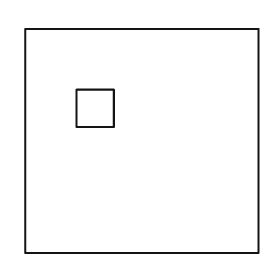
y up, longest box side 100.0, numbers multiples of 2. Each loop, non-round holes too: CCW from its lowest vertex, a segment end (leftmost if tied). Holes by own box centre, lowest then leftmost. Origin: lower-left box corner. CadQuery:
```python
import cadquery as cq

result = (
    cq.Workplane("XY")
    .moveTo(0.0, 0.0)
    .lineTo(100.0, 0.0)
    .lineTo(100.0, 96.0)
    .lineTo(0.0, 96.0)
    .close()
    .moveTo(22.0, 54.0)
    .lineTo(38.0, 54.0)
    .lineTo(38.0, 70.0)
    .lineTo(22.0, 70.0)
    .close()
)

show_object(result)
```